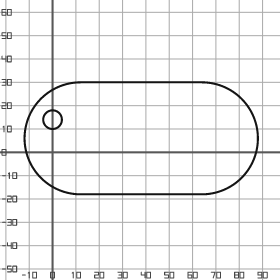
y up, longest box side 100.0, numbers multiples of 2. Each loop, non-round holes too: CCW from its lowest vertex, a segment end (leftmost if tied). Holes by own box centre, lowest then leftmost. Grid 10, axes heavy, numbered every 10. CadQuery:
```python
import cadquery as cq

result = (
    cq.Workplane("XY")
    .moveTo(12.0, -18.0)
    .lineTo(64.0, -18.0)
    .threePointArc((88.0, 6.0), (64.0, 30.0))
    .lineTo(12.0, 30.0)
    .threePointArc((-12.0, 6.0), (12.0, -18.0))
    .close()
    .moveTo(0.0, 14.0)
    .circle(4.0)
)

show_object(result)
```